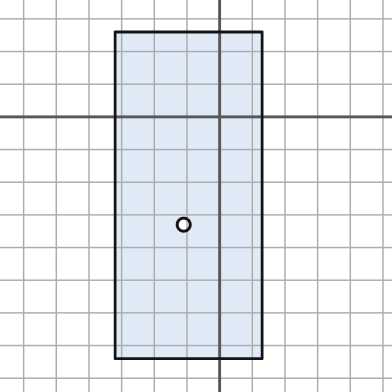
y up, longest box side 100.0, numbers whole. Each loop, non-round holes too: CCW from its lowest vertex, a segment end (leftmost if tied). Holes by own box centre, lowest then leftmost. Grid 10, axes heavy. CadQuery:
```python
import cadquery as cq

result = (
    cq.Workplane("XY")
    .moveTo(-32.0, -74.0)
    .lineTo(13.0, -74.0)
    .lineTo(13.0, 26.0)
    .lineTo(-32.0, 26.0)
    .close()
    .moveTo(-11.0, -33.0)
    .circle(2.0)
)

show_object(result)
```